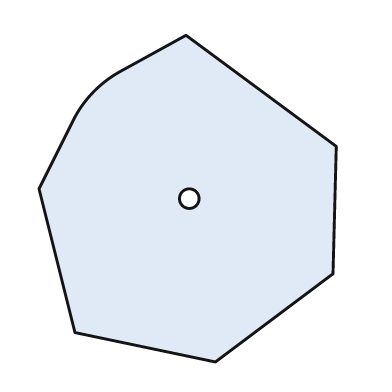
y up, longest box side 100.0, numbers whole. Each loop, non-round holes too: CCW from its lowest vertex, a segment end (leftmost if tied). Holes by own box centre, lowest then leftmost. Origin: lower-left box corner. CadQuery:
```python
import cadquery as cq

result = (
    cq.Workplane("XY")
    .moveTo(54.0, 0.0)
    .lineTo(90.0, 27.0)
    .lineTo(91.0, 66.0)
    .lineTo(45.0, 100.0)
    .lineTo(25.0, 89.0)
    .threePointArc((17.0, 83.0), (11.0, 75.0))
    .lineTo(0.0, 53.0)
    .lineTo(11.0, 9.0)
    .close()
    .moveTo(46.0, 50.0)
    .circle(3.0)
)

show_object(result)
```